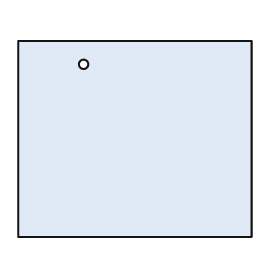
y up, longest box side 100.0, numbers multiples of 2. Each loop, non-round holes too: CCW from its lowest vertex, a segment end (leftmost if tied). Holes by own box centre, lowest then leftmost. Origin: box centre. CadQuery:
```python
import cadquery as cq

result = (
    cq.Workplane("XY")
    .moveTo(-50.0, -42.0)
    .lineTo(50.0, -42.0)
    .lineTo(50.0, 42.0)
    .lineTo(-50.0, 42.0)
    .close()
    .moveTo(-22.0, 32.0)
    .circle(2.0)
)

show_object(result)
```